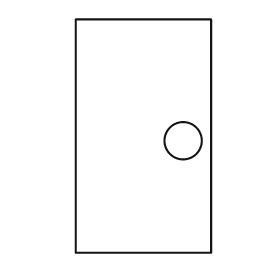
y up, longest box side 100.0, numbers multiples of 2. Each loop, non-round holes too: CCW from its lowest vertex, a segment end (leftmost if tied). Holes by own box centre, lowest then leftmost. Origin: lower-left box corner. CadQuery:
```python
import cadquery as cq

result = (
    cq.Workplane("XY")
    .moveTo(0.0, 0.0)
    .lineTo(58.0, 0.0)
    .lineTo(58.0, 100.0)
    .lineTo(0.0, 100.0)
    .close()
    .moveTo(46.0, 48.0)
    .circle(8.0)
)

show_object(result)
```